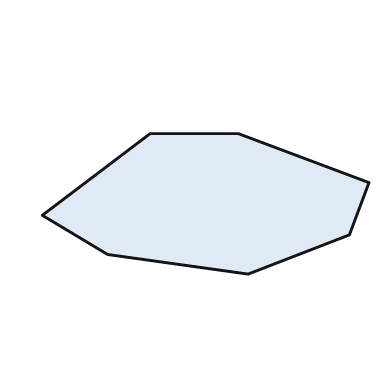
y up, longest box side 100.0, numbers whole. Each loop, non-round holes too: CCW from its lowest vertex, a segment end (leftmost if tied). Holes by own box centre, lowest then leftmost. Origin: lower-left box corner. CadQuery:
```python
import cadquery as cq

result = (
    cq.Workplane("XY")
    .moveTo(63.0, 0.0)
    .lineTo(94.0, 12.0)
    .lineTo(100.0, 28.0)
    .lineTo(60.0, 43.0)
    .lineTo(33.0, 43.0)
    .lineTo(0.0, 18.0)
    .lineTo(20.0, 6.0)
    .close()
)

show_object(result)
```